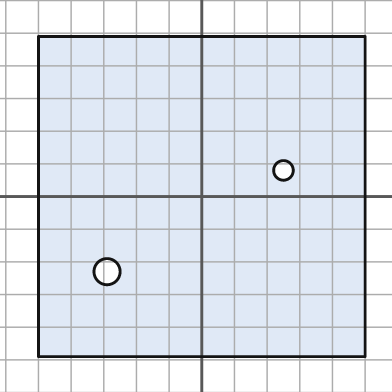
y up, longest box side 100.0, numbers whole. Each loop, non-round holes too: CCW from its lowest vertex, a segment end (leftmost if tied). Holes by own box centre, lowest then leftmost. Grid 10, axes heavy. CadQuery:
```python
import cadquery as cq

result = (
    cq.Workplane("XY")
    .moveTo(-50.0, -49.0)
    .lineTo(50.0, -49.0)
    .lineTo(50.0, 49.0)
    .lineTo(-50.0, 49.0)
    .close()
    .moveTo(-29.0, -23.0)
    .circle(4.0)
    .moveTo(25.0, 8.0)
    .circle(3.0)
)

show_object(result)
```